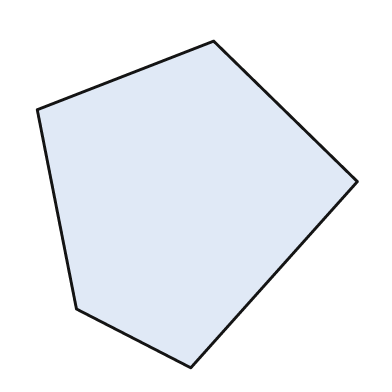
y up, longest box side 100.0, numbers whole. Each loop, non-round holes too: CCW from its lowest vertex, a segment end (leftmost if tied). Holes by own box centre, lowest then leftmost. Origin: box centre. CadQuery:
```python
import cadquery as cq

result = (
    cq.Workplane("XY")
    .moveTo(-2.0, -50.0)
    .lineTo(49.0, 7.0)
    .lineTo(5.0, 50.0)
    .lineTo(-49.0, 29.0)
    .lineTo(-37.0, -32.0)
    .close()
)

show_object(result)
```